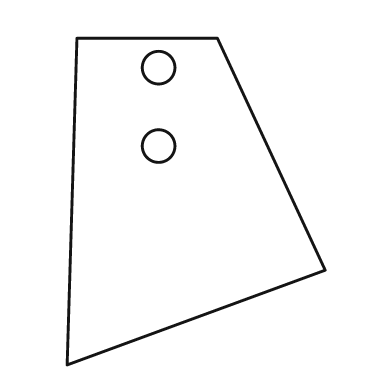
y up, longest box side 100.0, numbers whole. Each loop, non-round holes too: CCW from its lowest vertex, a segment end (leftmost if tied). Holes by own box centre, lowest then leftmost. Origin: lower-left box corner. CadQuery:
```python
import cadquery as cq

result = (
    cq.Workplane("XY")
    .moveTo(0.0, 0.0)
    .lineTo(79.0, 29.0)
    .lineTo(46.0, 100.0)
    .lineTo(3.0, 100.0)
    .close()
    .moveTo(28.0, 67.0)
    .circle(5.0)
    .moveTo(28.0, 91.0)
    .circle(5.0)
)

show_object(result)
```